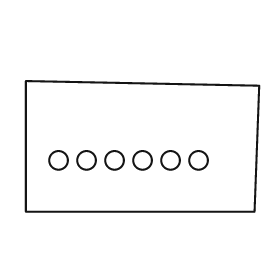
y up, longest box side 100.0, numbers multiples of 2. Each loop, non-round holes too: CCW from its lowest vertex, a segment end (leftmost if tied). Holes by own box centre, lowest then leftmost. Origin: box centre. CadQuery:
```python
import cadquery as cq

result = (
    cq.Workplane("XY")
    .moveTo(-50.0, -28.0)
    .lineTo(48.0, -28.0)
    .lineTo(50.0, 26.0)
    .lineTo(-50.0, 28.0)
    .close()
    .moveTo(-36.0, -6.0)
    .circle(4.0)
    .moveTo(-24.0, -6.0)
    .circle(4.0)
    .moveTo(-12.0, -6.0)
    .circle(4.0)
    .moveTo(0.0, -6.0)
    .circle(4.0)
    .moveTo(12.0, -6.0)
    .circle(4.0)
    .moveTo(24.0, -6.0)
    .circle(4.0)
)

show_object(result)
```